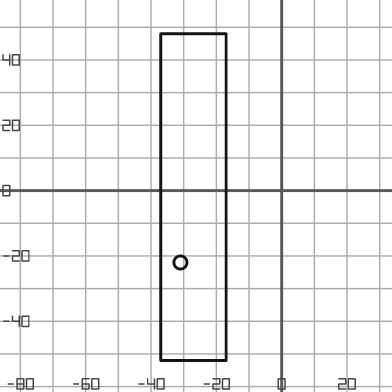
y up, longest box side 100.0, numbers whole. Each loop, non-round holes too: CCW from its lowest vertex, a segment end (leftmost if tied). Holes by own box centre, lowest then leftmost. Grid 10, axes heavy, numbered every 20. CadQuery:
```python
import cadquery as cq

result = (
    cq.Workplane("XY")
    .moveTo(-37.0, -52.0)
    .lineTo(-17.0, -52.0)
    .lineTo(-17.0, 48.0)
    .lineTo(-37.0, 48.0)
    .close()
    .moveTo(-31.0, -22.0)
    .circle(2.0)
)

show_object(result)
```